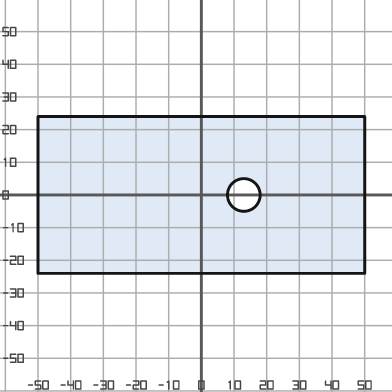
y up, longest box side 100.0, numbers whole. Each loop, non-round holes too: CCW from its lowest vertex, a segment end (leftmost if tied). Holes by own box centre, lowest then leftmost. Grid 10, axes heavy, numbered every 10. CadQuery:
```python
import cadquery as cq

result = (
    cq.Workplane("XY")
    .moveTo(-50.0, -24.0)
    .lineTo(50.0, -24.0)
    .lineTo(50.0, 24.0)
    .lineTo(-50.0, 24.0)
    .close()
    .moveTo(13.0, 0.0)
    .circle(5.0)
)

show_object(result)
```